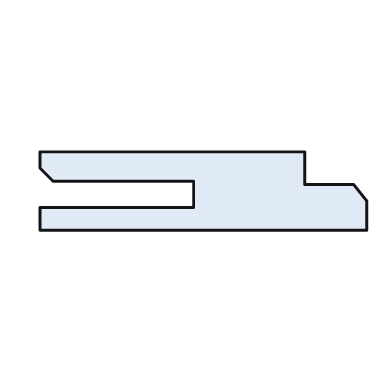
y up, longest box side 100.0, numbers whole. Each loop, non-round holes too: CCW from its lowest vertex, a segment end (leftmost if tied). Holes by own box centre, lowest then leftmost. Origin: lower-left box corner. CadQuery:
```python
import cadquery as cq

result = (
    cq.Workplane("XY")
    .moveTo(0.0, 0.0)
    .lineTo(100.0, 0.0)
    .lineTo(100.0, 9.0)
    .lineTo(96.0, 14.0)
    .lineTo(81.0, 14.0)
    .lineTo(81.0, 24.0)
    .lineTo(0.0, 24.0)
    .lineTo(0.0, 19.0)
    .lineTo(4.0, 15.0)
    .lineTo(47.0, 15.0)
    .lineTo(47.0, 7.0)
    .lineTo(0.0, 7.0)
    .close()
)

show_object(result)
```